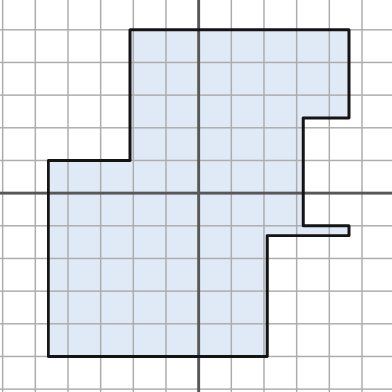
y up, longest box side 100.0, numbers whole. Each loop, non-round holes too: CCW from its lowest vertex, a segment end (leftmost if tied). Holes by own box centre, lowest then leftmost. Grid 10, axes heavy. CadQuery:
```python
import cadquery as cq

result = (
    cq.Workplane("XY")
    .moveTo(-46.0, -50.0)
    .lineTo(21.0, -50.0)
    .lineTo(21.0, -13.0)
    .lineTo(46.0, -13.0)
    .lineTo(46.0, -10.0)
    .lineTo(32.0, -10.0)
    .lineTo(32.0, 23.0)
    .lineTo(46.0, 23.0)
    .lineTo(46.0, 50.0)
    .lineTo(-21.0, 50.0)
    .lineTo(-21.0, 10.0)
    .lineTo(-46.0, 10.0)
    .close()
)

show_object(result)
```